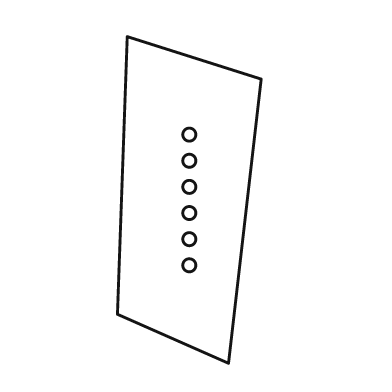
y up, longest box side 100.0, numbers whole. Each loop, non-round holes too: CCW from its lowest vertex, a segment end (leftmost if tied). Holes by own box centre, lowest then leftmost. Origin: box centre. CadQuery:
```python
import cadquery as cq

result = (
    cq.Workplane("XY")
    .moveTo(12.0, -50.0)
    .lineTo(22.0, 37.0)
    .lineTo(-19.0, 50.0)
    .lineTo(-22.0, -35.0)
    .close()
    .moveTo(0.0, -20.0)
    .circle(2.0)
    .moveTo(0.0, -12.0)
    .circle(2.0)
    .moveTo(0.0, -4.0)
    .circle(2.0)
    .moveTo(0.0, 4.0)
    .circle(2.0)
    .moveTo(0.0, 12.0)
    .circle(2.0)
    .moveTo(0.0, 20.0)
    .circle(2.0)
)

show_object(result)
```